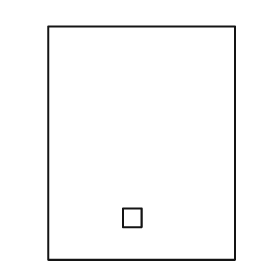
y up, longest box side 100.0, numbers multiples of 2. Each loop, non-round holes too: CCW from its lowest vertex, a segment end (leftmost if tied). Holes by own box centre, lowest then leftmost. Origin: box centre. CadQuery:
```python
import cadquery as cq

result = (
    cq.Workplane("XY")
    .moveTo(-40.0, -50.0)
    .lineTo(40.0, -50.0)
    .lineTo(40.0, 50.0)
    .lineTo(-40.0, 50.0)
    .close()
    .moveTo(-8.0, -36.0)
    .lineTo(0.0, -36.0)
    .lineTo(0.0, -28.0)
    .lineTo(-8.0, -28.0)
    .close()
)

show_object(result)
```